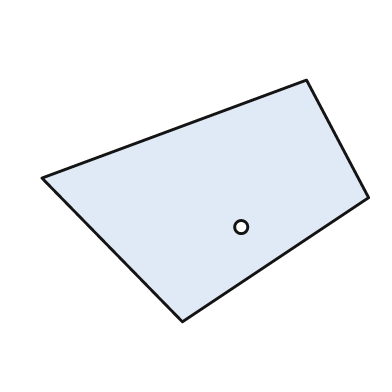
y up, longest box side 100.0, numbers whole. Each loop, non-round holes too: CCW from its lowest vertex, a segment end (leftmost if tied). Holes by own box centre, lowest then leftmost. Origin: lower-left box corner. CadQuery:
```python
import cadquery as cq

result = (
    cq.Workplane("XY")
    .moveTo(43.0, 0.0)
    .lineTo(100.0, 38.0)
    .lineTo(81.0, 74.0)
    .lineTo(0.0, 44.0)
    .close()
    .moveTo(61.0, 29.0)
    .circle(2.0)
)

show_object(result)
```